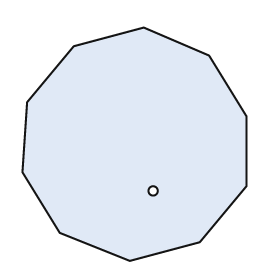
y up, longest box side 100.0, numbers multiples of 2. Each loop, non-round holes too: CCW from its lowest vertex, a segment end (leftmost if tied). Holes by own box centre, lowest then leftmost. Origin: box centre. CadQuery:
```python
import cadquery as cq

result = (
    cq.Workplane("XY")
    .moveTo(-2.0, -50.0)
    .lineTo(28.0, -42.0)
    .lineTo(48.0, -18.0)
    .lineTo(48.0, 12.0)
    .lineTo(32.0, 38.0)
    .lineTo(4.0, 50.0)
    .lineTo(-26.0, 42.0)
    .lineTo(-46.0, 18.0)
    .lineTo(-48.0, -12.0)
    .lineTo(-32.0, -38.0)
    .close()
    .moveTo(8.0, -20.0)
    .circle(2.0)
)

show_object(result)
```